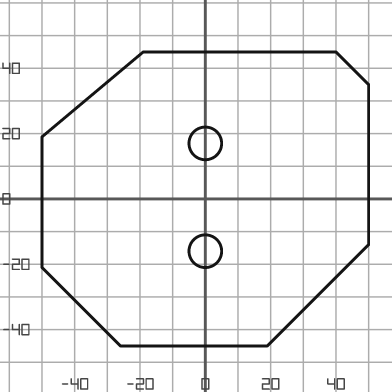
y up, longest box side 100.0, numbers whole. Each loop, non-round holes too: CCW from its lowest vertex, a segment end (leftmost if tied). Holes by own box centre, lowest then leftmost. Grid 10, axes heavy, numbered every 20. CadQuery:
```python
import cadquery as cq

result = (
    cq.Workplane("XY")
    .moveTo(-26.0, -45.0)
    .lineTo(19.0, -45.0)
    .lineTo(50.0, -14.0)
    .lineTo(50.0, 35.0)
    .lineTo(40.0, 45.0)
    .lineTo(-19.0, 45.0)
    .lineTo(-50.0, 19.0)
    .lineTo(-50.0, -21.0)
    .close()
    .moveTo(0.0, -16.0)
    .circle(5.0)
    .moveTo(0.0, 17.0)
    .circle(5.0)
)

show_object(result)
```